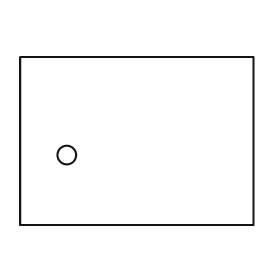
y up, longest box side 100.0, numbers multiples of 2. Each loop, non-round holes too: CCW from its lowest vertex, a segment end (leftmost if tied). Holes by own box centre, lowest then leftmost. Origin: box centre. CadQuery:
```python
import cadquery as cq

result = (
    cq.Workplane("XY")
    .moveTo(-50.0, -36.0)
    .lineTo(50.0, -36.0)
    .lineTo(50.0, 36.0)
    .lineTo(-50.0, 36.0)
    .close()
    .moveTo(-30.0, -6.0)
    .circle(4.0)
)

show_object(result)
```